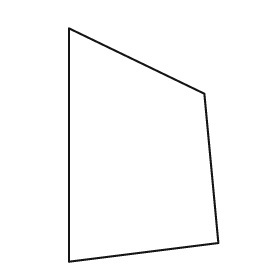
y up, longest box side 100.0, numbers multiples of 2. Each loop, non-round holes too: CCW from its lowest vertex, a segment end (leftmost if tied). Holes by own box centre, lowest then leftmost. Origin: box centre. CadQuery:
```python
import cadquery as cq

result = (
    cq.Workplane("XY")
    .moveTo(-32.0, -50.0)
    .lineTo(32.0, -42.0)
    .lineTo(26.0, 22.0)
    .lineTo(-32.0, 50.0)
    .close()
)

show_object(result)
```